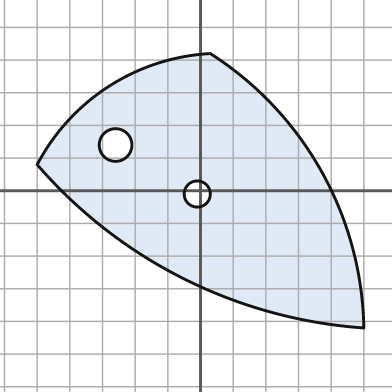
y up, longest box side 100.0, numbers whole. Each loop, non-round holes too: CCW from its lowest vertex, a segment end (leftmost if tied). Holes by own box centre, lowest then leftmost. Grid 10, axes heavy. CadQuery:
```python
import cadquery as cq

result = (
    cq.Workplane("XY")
    .moveTo(50.0, -42.0)
    .threePointArc((37.0, 6.0), (3.0, 42.0))
    .threePointArc((-28.0, 32.0), (-50.0, 8.0))
    .threePointArc((-5.0, -27.0), (50.0, -42.0))
    .close()
    .moveTo(-1.0, -1.0)
    .circle(4.0)
    .moveTo(-26.0, 14.0)
    .circle(5.0)
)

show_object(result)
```